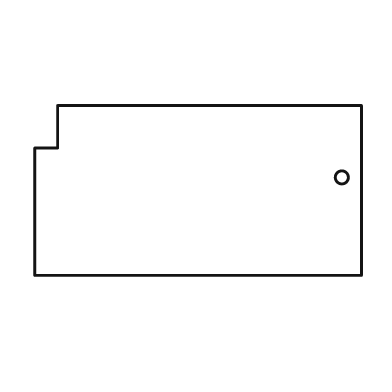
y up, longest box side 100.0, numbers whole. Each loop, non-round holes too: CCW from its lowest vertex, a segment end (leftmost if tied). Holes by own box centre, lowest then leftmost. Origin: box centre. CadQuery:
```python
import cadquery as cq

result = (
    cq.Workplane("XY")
    .moveTo(-50.0, -26.0)
    .lineTo(50.0, -26.0)
    .lineTo(50.0, 26.0)
    .lineTo(-43.0, 26.0)
    .lineTo(-43.0, 13.0)
    .lineTo(-50.0, 13.0)
    .close()
    .moveTo(44.0, 4.0)
    .circle(2.0)
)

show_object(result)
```